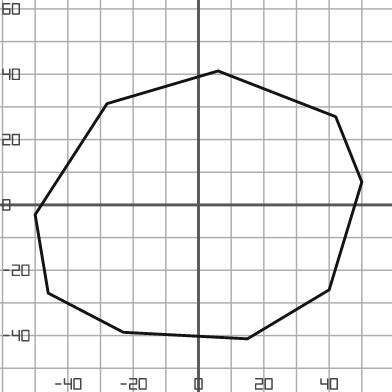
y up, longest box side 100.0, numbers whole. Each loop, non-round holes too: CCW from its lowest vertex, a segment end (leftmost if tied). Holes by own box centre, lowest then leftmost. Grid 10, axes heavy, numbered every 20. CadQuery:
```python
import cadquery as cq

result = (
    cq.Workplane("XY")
    .moveTo(15.0, -41.0)
    .lineTo(40.0, -26.0)
    .lineTo(50.0, 7.0)
    .lineTo(42.0, 27.0)
    .lineTo(6.0, 41.0)
    .lineTo(-28.0, 31.0)
    .lineTo(-50.0, -3.0)
    .lineTo(-46.0, -27.0)
    .lineTo(-23.0, -39.0)
    .close()
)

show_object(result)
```